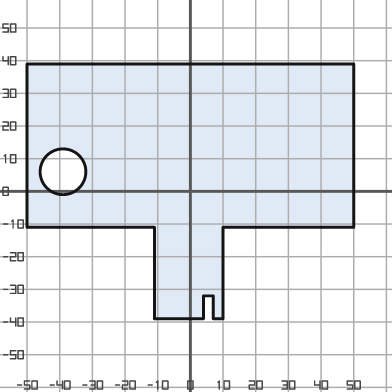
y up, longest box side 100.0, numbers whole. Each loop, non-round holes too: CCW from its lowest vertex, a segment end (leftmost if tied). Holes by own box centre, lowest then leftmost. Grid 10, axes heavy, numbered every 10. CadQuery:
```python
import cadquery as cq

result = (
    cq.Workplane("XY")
    .moveTo(-11.0, -39.0)
    .lineTo(4.0, -39.0)
    .lineTo(4.0, -32.0)
    .lineTo(7.0, -32.0)
    .lineTo(7.0, -39.0)
    .lineTo(10.0, -39.0)
    .lineTo(10.0, -11.0)
    .lineTo(50.0, -11.0)
    .lineTo(50.0, 39.0)
    .lineTo(-50.0, 39.0)
    .lineTo(-50.0, -11.0)
    .lineTo(-11.0, -11.0)
    .close()
    .moveTo(-39.0, 6.0)
    .circle(7.0)
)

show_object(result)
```